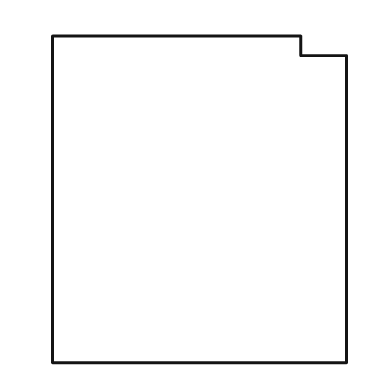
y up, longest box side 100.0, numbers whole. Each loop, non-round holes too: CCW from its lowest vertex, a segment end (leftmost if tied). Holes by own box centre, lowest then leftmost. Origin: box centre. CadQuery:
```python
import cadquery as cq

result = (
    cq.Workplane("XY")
    .moveTo(-45.0, -50.0)
    .lineTo(45.0, -50.0)
    .lineTo(45.0, 44.0)
    .lineTo(31.0, 44.0)
    .lineTo(31.0, 50.0)
    .lineTo(-45.0, 50.0)
    .close()
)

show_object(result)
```